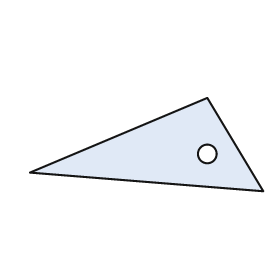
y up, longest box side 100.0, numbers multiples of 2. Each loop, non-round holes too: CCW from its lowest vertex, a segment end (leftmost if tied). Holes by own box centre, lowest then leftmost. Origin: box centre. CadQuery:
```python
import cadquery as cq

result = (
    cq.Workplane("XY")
    .moveTo(50.0, -20.0)
    .lineTo(26.0, 20.0)
    .lineTo(-50.0, -12.0)
    .close()
    .moveTo(26.0, -4.0)
    .circle(4.0)
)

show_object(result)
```